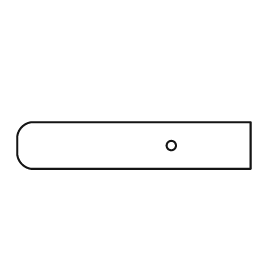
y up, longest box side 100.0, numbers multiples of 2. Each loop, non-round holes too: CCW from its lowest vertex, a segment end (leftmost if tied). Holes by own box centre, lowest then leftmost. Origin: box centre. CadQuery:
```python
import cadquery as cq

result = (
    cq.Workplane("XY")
    .moveTo(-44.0, -10.0)
    .lineTo(50.0, -10.0)
    .lineTo(50.0, 10.0)
    .lineTo(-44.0, 10.0)
    .threePointArc((-48.0, 8.0), (-50.0, 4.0))
    .lineTo(-50.0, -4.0)
    .threePointArc((-48.0, -8.0), (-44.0, -10.0))
    .close()
    .moveTo(16.0, 0.0)
    .circle(2.0)
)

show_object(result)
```